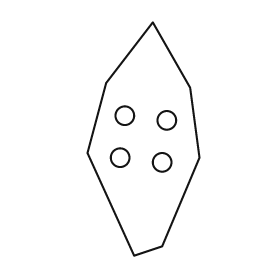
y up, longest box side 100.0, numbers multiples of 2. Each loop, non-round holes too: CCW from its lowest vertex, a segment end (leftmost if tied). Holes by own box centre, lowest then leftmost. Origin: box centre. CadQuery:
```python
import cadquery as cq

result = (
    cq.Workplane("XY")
    .moveTo(-4.0, -50.0)
    .lineTo(8.0, -46.0)
    .lineTo(24.0, -8.0)
    .lineTo(20.0, 22.0)
    .lineTo(4.0, 50.0)
    .lineTo(-16.0, 24.0)
    .lineTo(-24.0, -6.0)
    .close()
    .moveTo(8.0, -10.0)
    .circle(4.0)
    .moveTo(-10.0, -8.0)
    .circle(4.0)
    .moveTo(10.0, 8.0)
    .circle(4.0)
    .moveTo(-8.0, 10.0)
    .circle(4.0)
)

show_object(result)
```